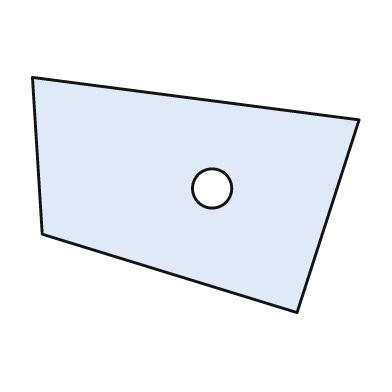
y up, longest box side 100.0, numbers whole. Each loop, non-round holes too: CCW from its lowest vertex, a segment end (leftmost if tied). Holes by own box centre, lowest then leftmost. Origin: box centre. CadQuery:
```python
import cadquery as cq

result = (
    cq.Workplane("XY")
    .moveTo(31.0, -36.0)
    .lineTo(50.0, 23.0)
    .lineTo(-50.0, 36.0)
    .lineTo(-47.0, -12.0)
    .close()
    .moveTo(5.0, 2.0)
    .circle(6.0)
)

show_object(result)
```